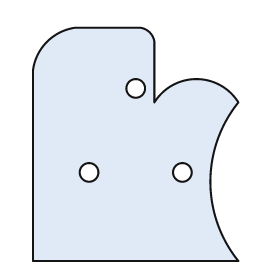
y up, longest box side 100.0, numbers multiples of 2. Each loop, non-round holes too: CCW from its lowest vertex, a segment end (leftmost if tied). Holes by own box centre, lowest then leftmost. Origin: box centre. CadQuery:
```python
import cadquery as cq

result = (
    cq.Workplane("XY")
    .moveTo(-44.0, -50.0)
    .lineTo(44.0, -50.0)
    .threePointArc((32.0, -16.0), (44.0, 18.0))
    .threePointArc((26.0, 28.0), (8.0, 18.0))
    .lineTo(8.0, 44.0)
    .threePointArc((6.0, 48.0), (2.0, 50.0))
    .lineTo(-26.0, 50.0)
    .threePointArc((-38.0, 44.0), (-44.0, 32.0))
    .close()
    .moveTo(-20.0, -12.0)
    .circle(4.0)
    .moveTo(20.0, -12.0)
    .circle(4.0)
    .moveTo(0.0, 24.0)
    .circle(4.0)
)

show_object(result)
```